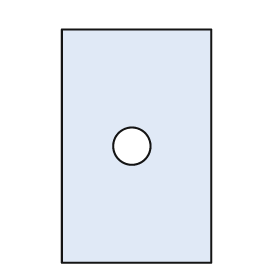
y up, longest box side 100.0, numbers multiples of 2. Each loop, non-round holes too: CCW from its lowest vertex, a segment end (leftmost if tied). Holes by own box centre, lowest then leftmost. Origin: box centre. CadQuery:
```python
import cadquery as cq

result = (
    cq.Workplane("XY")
    .moveTo(-32.0, -50.0)
    .lineTo(32.0, -50.0)
    .lineTo(32.0, 50.0)
    .lineTo(-32.0, 50.0)
    .close()
    .moveTo(-2.0, 0.0)
    .circle(8.0)
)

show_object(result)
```